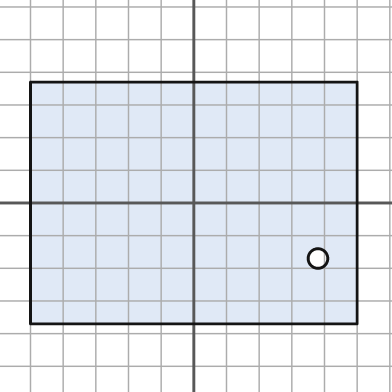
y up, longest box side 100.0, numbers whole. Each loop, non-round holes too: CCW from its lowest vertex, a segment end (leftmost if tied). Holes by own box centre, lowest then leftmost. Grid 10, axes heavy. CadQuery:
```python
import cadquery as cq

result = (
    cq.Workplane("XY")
    .moveTo(-50.0, -37.0)
    .lineTo(50.0, -37.0)
    .lineTo(50.0, 37.0)
    .lineTo(-50.0, 37.0)
    .close()
    .moveTo(38.0, -17.0)
    .circle(3.0)
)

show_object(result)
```